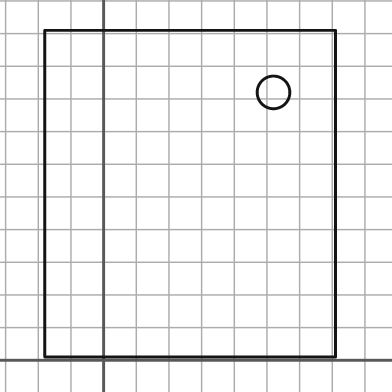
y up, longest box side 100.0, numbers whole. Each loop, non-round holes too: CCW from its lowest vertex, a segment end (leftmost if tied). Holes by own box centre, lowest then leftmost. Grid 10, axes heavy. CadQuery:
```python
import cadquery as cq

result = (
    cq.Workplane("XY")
    .moveTo(-18.0, 1.0)
    .lineTo(71.0, 1.0)
    .lineTo(71.0, 101.0)
    .lineTo(-18.0, 101.0)
    .close()
    .moveTo(52.0, 82.0)
    .circle(5.0)
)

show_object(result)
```